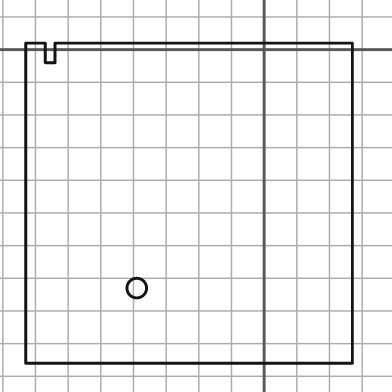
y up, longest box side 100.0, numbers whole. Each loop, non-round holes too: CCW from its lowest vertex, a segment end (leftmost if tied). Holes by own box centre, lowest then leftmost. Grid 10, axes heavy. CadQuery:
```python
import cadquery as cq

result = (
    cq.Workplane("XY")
    .moveTo(-73.0, -96.0)
    .lineTo(27.0, -96.0)
    .lineTo(27.0, 2.0)
    .lineTo(-64.0, 2.0)
    .lineTo(-64.0, -4.0)
    .lineTo(-67.0, -4.0)
    .lineTo(-67.0, 2.0)
    .lineTo(-73.0, 2.0)
    .close()
    .moveTo(-39.0, -73.0)
    .circle(3.0)
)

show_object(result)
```